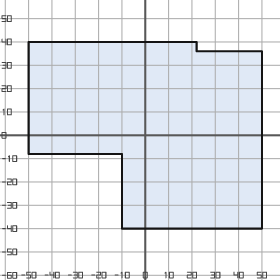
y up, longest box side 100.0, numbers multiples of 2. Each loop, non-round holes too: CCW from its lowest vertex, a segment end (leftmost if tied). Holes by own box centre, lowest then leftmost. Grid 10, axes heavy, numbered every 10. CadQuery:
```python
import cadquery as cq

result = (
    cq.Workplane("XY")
    .moveTo(-10.0, -40.0)
    .lineTo(50.0, -40.0)
    .lineTo(50.0, 36.0)
    .lineTo(22.0, 36.0)
    .lineTo(22.0, 40.0)
    .lineTo(-50.0, 40.0)
    .lineTo(-50.0, -8.0)
    .lineTo(-10.0, -8.0)
    .close()
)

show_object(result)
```